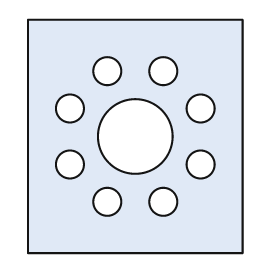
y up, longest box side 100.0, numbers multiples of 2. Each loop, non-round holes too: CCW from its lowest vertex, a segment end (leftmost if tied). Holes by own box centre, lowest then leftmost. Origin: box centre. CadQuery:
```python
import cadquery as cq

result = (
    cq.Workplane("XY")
    .moveTo(-46.0, -50.0)
    .lineTo(46.0, -50.0)
    .lineTo(46.0, 50.0)
    .lineTo(-46.0, 50.0)
    .close()
    .moveTo(-12.0, -28.0)
    .circle(6.0)
    .moveTo(12.0, -28.0)
    .circle(6.0)
    .moveTo(-28.0, -12.0)
    .circle(6.0)
    .moveTo(28.0, -12.0)
    .circle(6.0)
    .moveTo(0.0, 0.0)
    .circle(16.0)
    .moveTo(-28.0, 12.0)
    .circle(6.0)
    .moveTo(28.0, 12.0)
    .circle(6.0)
    .moveTo(-12.0, 28.0)
    .circle(6.0)
    .moveTo(12.0, 28.0)
    .circle(6.0)
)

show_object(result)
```